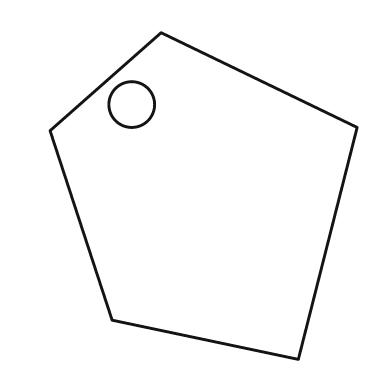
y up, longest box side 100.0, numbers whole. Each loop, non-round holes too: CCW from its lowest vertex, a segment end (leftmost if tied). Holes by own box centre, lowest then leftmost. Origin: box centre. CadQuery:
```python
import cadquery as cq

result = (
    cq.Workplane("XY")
    .moveTo(29.0, -50.0)
    .lineTo(47.0, 21.0)
    .lineTo(-13.0, 50.0)
    .lineTo(-47.0, 20.0)
    .lineTo(-28.0, -38.0)
    .close()
    .moveTo(-22.0, 28.0)
    .circle(7.0)
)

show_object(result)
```